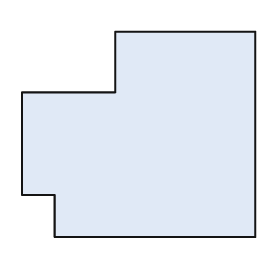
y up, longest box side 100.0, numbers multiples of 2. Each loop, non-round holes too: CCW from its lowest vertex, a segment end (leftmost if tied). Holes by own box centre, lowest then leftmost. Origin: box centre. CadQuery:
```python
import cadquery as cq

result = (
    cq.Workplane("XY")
    .moveTo(-36.0, -44.0)
    .lineTo(50.0, -44.0)
    .lineTo(50.0, 44.0)
    .lineTo(-10.0, 44.0)
    .lineTo(-10.0, 18.0)
    .lineTo(-50.0, 18.0)
    .lineTo(-50.0, -26.0)
    .lineTo(-36.0, -26.0)
    .close()
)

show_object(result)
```